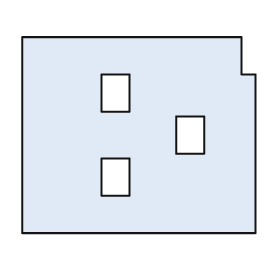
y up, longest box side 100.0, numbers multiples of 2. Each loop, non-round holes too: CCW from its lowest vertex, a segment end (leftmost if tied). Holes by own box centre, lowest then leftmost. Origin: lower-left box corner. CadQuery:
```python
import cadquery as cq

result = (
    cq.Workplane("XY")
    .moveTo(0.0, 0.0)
    .lineTo(100.0, 0.0)
    .lineTo(100.0, 68.0)
    .lineTo(94.0, 68.0)
    .lineTo(94.0, 84.0)
    .lineTo(0.0, 84.0)
    .close()
    .moveTo(34.0, 16.0)
    .lineTo(46.0, 16.0)
    .lineTo(46.0, 32.0)
    .lineTo(34.0, 32.0)
    .close()
    .moveTo(66.0, 34.0)
    .lineTo(78.0, 34.0)
    .lineTo(78.0, 50.0)
    .lineTo(66.0, 50.0)
    .close()
    .moveTo(34.0, 52.0)
    .lineTo(46.0, 52.0)
    .lineTo(46.0, 68.0)
    .lineTo(34.0, 68.0)
    .close()
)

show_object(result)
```